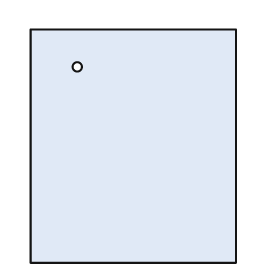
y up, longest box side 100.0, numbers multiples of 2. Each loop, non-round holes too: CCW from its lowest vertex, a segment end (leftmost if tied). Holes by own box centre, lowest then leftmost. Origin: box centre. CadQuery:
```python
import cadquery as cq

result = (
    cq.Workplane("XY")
    .moveTo(-44.0, -50.0)
    .lineTo(44.0, -50.0)
    .lineTo(44.0, 50.0)
    .lineTo(-44.0, 50.0)
    .close()
    .moveTo(-24.0, 34.0)
    .circle(2.0)
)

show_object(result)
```